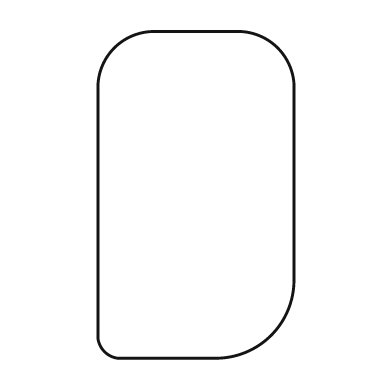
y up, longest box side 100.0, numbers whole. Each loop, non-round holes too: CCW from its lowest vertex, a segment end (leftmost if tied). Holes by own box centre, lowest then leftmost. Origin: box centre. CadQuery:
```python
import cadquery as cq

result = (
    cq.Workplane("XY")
    .moveTo(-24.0, -50.0)
    .lineTo(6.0, -50.0)
    .threePointArc((23.0, -43.0), (30.0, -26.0))
    .lineTo(30.0, 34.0)
    .threePointArc((25.0, 45.0), (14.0, 50.0))
    .lineTo(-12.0, 50.0)
    .threePointArc((-25.0, 45.0), (-30.0, 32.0))
    .lineTo(-30.0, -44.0)
    .threePointArc((-28.0, -48.0), (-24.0, -50.0))
    .close()
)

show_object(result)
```